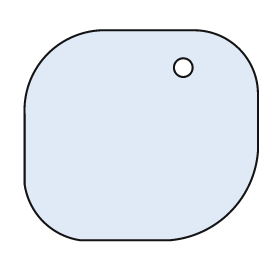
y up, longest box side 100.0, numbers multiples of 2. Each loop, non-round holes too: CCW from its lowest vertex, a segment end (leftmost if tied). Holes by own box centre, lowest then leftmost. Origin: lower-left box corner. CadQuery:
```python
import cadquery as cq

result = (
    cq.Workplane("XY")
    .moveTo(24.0, 0.0)
    .lineTo(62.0, 0.0)
    .threePointArc((88.0, 12.0), (100.0, 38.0))
    .lineTo(100.0, 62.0)
    .threePointArc((92.0, 82.0), (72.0, 90.0))
    .lineTo(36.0, 90.0)
    .threePointArc((10.0, 80.0), (0.0, 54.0))
    .lineTo(0.0, 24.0)
    .threePointArc((8.0, 8.0), (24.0, 0.0))
    .close()
    .moveTo(68.0, 74.0)
    .circle(4.0)
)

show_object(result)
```